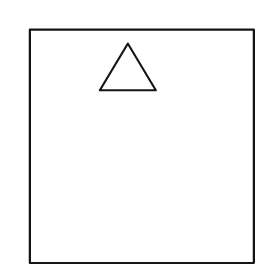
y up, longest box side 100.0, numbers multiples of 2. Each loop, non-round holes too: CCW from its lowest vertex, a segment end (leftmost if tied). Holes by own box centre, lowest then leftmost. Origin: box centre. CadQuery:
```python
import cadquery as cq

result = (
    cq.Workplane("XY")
    .moveTo(-48.0, -50.0)
    .lineTo(48.0, -50.0)
    .lineTo(48.0, 50.0)
    .lineTo(-48.0, 50.0)
    .close()
    .moveTo(-18.0, 24.0)
    .lineTo(6.0, 24.0)
    .lineTo(-6.0, 44.0)
    .close()
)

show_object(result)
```